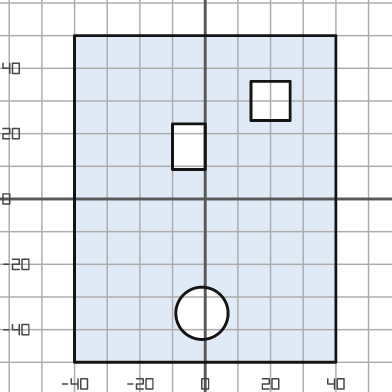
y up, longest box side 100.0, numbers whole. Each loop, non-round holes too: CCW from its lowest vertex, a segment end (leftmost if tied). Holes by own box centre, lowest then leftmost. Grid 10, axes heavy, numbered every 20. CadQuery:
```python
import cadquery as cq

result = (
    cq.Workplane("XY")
    .moveTo(-40.0, -50.0)
    .lineTo(40.0, -50.0)
    .lineTo(40.0, 50.0)
    .lineTo(-40.0, 50.0)
    .close()
    .moveTo(-1.0, -35.0)
    .circle(8.0)
    .moveTo(-10.0, 9.0)
    .lineTo(0.0, 9.0)
    .lineTo(0.0, 23.0)
    .lineTo(-10.0, 23.0)
    .close()
    .moveTo(14.0, 24.0)
    .lineTo(26.0, 24.0)
    .lineTo(26.0, 36.0)
    .lineTo(14.0, 36.0)
    .close()
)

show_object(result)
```